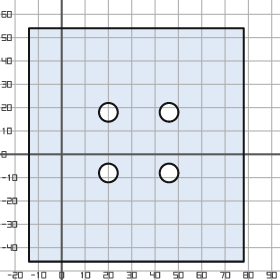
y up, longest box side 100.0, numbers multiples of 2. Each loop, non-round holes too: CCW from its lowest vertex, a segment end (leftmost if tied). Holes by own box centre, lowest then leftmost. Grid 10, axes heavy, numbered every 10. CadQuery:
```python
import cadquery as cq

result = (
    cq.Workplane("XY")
    .moveTo(-14.0, -46.0)
    .lineTo(78.0, -46.0)
    .lineTo(78.0, 54.0)
    .lineTo(-14.0, 54.0)
    .close()
    .moveTo(20.0, -8.0)
    .circle(4.0)
    .moveTo(46.0, -8.0)
    .circle(4.0)
    .moveTo(20.0, 18.0)
    .circle(4.0)
    .moveTo(46.0, 18.0)
    .circle(4.0)
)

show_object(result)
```